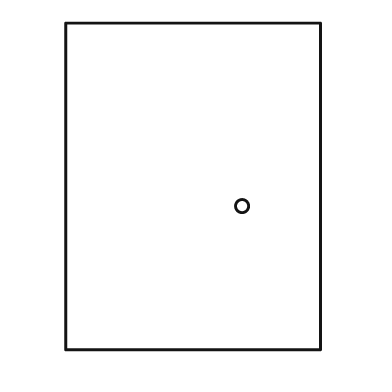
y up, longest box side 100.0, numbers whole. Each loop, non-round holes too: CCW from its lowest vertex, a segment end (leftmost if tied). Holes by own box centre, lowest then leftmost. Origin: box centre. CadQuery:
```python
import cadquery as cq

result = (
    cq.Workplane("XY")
    .moveTo(-39.0, -50.0)
    .lineTo(39.0, -50.0)
    .lineTo(39.0, 50.0)
    .lineTo(-39.0, 50.0)
    .close()
    .moveTo(15.0, -6.0)
    .circle(2.0)
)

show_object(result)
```